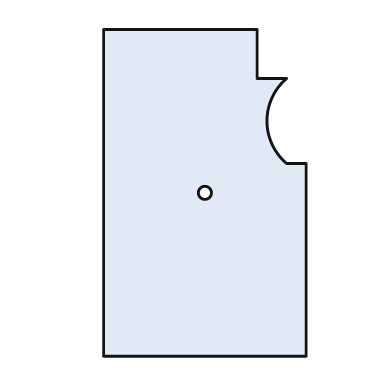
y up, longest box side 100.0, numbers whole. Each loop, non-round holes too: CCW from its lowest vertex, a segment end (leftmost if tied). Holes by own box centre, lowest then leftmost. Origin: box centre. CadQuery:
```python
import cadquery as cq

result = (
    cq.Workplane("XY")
    .moveTo(-31.0, -50.0)
    .lineTo(31.0, -50.0)
    .lineTo(31.0, 9.0)
    .lineTo(25.0, 9.0)
    .threePointArc((19.0, 22.0), (25.0, 35.0))
    .lineTo(16.0, 35.0)
    .lineTo(16.0, 50.0)
    .lineTo(-31.0, 50.0)
    .close()
    .moveTo(0.0, 0.0)
    .circle(2.0)
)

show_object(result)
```